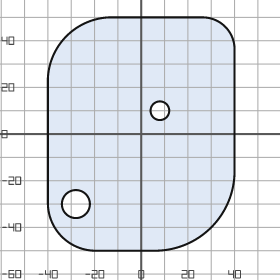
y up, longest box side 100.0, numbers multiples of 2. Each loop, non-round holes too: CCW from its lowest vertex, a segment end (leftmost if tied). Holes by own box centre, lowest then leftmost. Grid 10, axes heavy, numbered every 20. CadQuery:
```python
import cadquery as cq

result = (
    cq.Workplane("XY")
    .moveTo(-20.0, -50.0)
    .lineTo(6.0, -50.0)
    .threePointArc((30.0, -40.0), (40.0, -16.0))
    .lineTo(40.0, 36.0)
    .threePointArc((36.0, 46.0), (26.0, 50.0))
    .lineTo(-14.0, 50.0)
    .threePointArc((-32.0, 42.0), (-40.0, 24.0))
    .lineTo(-40.0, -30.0)
    .threePointArc((-34.0, -44.0), (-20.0, -50.0))
    .close()
    .moveTo(-28.0, -30.0)
    .circle(6.0)
    .moveTo(8.0, 10.0)
    .circle(4.0)
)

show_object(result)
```